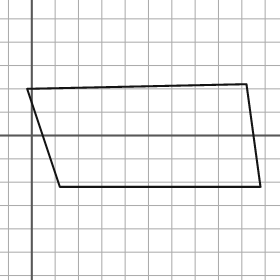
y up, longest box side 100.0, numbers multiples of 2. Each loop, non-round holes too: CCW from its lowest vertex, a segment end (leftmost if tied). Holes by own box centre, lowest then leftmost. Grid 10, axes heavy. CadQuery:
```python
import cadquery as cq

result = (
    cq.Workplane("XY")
    .moveTo(12.0, -22.0)
    .lineTo(98.0, -22.0)
    .lineTo(92.0, 22.0)
    .lineTo(-2.0, 20.0)
    .close()
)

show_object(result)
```